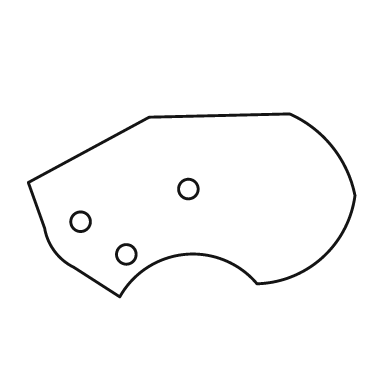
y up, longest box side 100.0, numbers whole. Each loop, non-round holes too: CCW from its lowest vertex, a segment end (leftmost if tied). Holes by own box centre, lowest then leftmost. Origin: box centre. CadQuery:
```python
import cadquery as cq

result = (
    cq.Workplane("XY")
    .moveTo(-22.0, -28.0)
    .threePointArc((-2.0, -15.0), (20.0, -24.0))
    .threePointArc((40.0, -16.0), (50.0, 3.0))
    .threePointArc((43.0, 18.0), (30.0, 28.0))
    .lineTo(-13.0, 27.0)
    .lineTo(-50.0, 7.0)
    .lineTo(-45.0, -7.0)
    .threePointArc((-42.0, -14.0), (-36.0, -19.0))
    .close()
    .moveTo(-20.0, -15.0)
    .circle(3.0)
    .moveTo(-34.0, -5.0)
    .circle(3.0)
    .moveTo(-1.0, 5.0)
    .circle(3.0)
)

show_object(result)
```